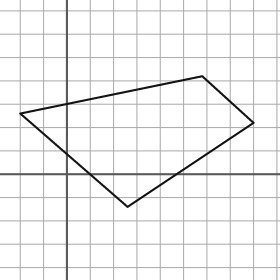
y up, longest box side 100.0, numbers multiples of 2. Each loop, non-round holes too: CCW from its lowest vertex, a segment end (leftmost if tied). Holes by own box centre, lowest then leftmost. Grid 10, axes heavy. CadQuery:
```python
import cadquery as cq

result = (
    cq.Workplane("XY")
    .moveTo(26.0, -14.0)
    .lineTo(80.0, 22.0)
    .lineTo(58.0, 42.0)
    .lineTo(-20.0, 26.0)
    .close()
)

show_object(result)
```